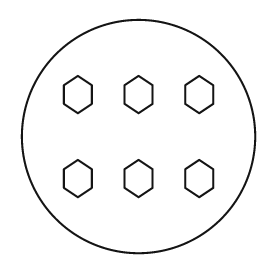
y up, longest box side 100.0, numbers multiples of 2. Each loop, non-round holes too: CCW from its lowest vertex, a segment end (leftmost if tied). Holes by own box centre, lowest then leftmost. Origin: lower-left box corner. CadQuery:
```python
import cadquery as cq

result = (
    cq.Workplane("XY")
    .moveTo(50.0, 50.0)
    .circle(50.0)
    .moveTo(24.0, 24.0)
    .lineTo(30.0, 28.0)
    .lineTo(30.0, 36.0)
    .lineTo(24.0, 40.0)
    .lineTo(18.0, 36.0)
    .lineTo(18.0, 28.0)
    .close()
    .moveTo(50.0, 24.0)
    .lineTo(56.0, 28.0)
    .lineTo(56.0, 36.0)
    .lineTo(50.0, 40.0)
    .lineTo(44.0, 36.0)
    .lineTo(44.0, 28.0)
    .close()
    .moveTo(76.0, 24.0)
    .lineTo(82.0, 28.0)
    .lineTo(82.0, 36.0)
    .lineTo(76.0, 40.0)
    .lineTo(70.0, 36.0)
    .lineTo(70.0, 28.0)
    .close()
    .moveTo(24.0, 60.0)
    .lineTo(30.0, 64.0)
    .lineTo(30.0, 72.0)
    .lineTo(24.0, 76.0)
    .lineTo(18.0, 72.0)
    .lineTo(18.0, 64.0)
    .close()
    .moveTo(50.0, 60.0)
    .lineTo(56.0, 64.0)
    .lineTo(56.0, 72.0)
    .lineTo(50.0, 76.0)
    .lineTo(44.0, 72.0)
    .lineTo(44.0, 64.0)
    .close()
    .moveTo(76.0, 60.0)
    .lineTo(82.0, 64.0)
    .lineTo(82.0, 72.0)
    .lineTo(76.0, 76.0)
    .lineTo(70.0, 72.0)
    .lineTo(70.0, 64.0)
    .close()
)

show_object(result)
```